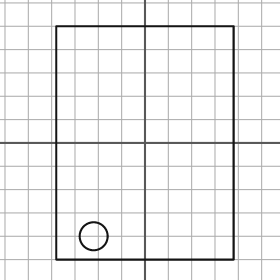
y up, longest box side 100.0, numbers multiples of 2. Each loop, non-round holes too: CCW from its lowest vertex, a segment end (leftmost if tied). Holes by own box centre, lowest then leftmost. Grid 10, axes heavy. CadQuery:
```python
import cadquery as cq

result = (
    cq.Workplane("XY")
    .moveTo(-38.0, -50.0)
    .lineTo(38.0, -50.0)
    .lineTo(38.0, 50.0)
    .lineTo(-38.0, 50.0)
    .close()
    .moveTo(-22.0, -40.0)
    .circle(6.0)
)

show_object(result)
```